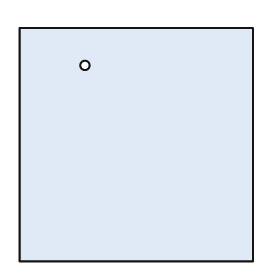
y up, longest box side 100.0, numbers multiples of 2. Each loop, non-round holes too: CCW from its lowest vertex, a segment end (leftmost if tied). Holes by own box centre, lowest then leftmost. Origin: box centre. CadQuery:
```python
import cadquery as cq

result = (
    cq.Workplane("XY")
    .moveTo(-50.0, -50.0)
    .lineTo(50.0, -50.0)
    .lineTo(50.0, 50.0)
    .lineTo(-50.0, 50.0)
    .close()
    .moveTo(-22.0, 34.0)
    .circle(2.0)
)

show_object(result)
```